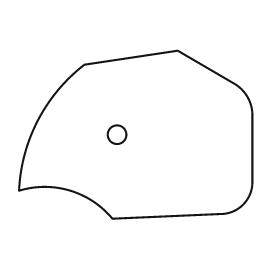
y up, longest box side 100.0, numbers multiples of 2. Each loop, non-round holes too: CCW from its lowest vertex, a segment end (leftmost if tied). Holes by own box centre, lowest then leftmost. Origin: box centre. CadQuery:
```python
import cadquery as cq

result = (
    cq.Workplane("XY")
    .moveTo(-10.0, -36.0)
    .lineTo(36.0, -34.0)
    .threePointArc((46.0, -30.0), (50.0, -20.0))
    .lineTo(50.0, 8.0)
    .threePointArc((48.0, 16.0), (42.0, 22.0))
    .lineTo(18.0, 36.0)
    .lineTo(-22.0, 30.0)
    .threePointArc((-42.0, 6.0), (-50.0, -24.0))
    .threePointArc((-28.0, -24.0), (-10.0, -36.0))
    .close()
    .moveTo(-8.0, 0.0)
    .circle(4.0)
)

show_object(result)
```